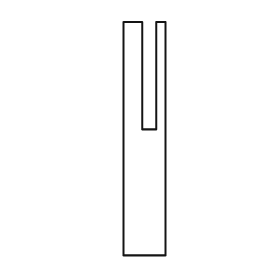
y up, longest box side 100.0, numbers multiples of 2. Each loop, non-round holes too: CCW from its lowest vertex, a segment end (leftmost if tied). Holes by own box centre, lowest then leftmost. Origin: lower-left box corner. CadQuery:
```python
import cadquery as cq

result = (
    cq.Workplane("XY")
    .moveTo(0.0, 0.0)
    .lineTo(18.0, 0.0)
    .lineTo(18.0, 100.0)
    .lineTo(14.0, 100.0)
    .lineTo(14.0, 54.0)
    .lineTo(8.0, 54.0)
    .lineTo(8.0, 100.0)
    .lineTo(0.0, 100.0)
    .close()
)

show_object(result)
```